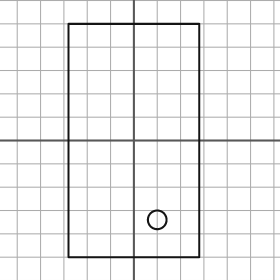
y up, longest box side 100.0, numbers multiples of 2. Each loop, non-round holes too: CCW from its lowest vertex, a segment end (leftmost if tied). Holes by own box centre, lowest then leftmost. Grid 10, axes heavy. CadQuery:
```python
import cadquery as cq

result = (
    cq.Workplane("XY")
    .moveTo(-28.0, -50.0)
    .lineTo(28.0, -50.0)
    .lineTo(28.0, 50.0)
    .lineTo(-28.0, 50.0)
    .close()
    .moveTo(10.0, -34.0)
    .circle(4.0)
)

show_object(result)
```